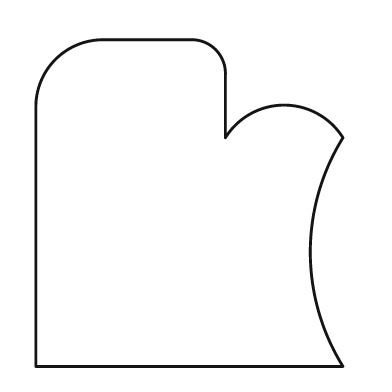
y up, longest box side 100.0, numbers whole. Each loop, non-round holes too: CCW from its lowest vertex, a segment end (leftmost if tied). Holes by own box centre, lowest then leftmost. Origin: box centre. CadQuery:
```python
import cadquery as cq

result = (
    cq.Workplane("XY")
    .moveTo(-47.0, -50.0)
    .lineTo(47.0, -50.0)
    .threePointArc((37.0, -15.0), (47.0, 20.0))
    .threePointArc((29.0, 30.0), (11.0, 20.0))
    .lineTo(11.0, 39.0)
    .threePointArc((8.0, 47.0), (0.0, 50.0))
    .lineTo(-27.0, 50.0)
    .threePointArc((-41.0, 44.0), (-47.0, 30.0))
    .close()
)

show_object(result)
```